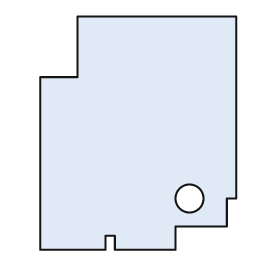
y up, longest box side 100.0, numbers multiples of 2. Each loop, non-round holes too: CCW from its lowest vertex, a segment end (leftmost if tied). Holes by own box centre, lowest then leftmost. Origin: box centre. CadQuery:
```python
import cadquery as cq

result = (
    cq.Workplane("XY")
    .moveTo(-42.0, -50.0)
    .lineTo(-14.0, -50.0)
    .lineTo(-14.0, -44.0)
    .lineTo(-10.0, -44.0)
    .lineTo(-10.0, -50.0)
    .lineTo(16.0, -50.0)
    .lineTo(16.0, -40.0)
    .lineTo(38.0, -40.0)
    .lineTo(38.0, -28.0)
    .lineTo(42.0, -28.0)
    .lineTo(42.0, 50.0)
    .lineTo(-26.0, 50.0)
    .lineTo(-26.0, 24.0)
    .lineTo(-42.0, 24.0)
    .close()
    .moveTo(22.0, -28.0)
    .circle(6.0)
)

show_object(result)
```